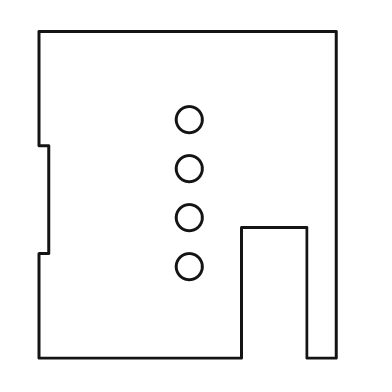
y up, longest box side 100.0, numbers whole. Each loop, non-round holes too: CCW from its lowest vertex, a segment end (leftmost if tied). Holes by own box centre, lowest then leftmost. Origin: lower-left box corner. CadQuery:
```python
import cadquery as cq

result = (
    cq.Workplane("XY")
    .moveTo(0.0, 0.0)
    .lineTo(62.0, 0.0)
    .lineTo(62.0, 40.0)
    .lineTo(82.0, 40.0)
    .lineTo(82.0, 0.0)
    .lineTo(91.0, 0.0)
    .lineTo(91.0, 100.0)
    .lineTo(0.0, 100.0)
    .lineTo(0.0, 65.0)
    .lineTo(3.0, 65.0)
    .lineTo(3.0, 32.0)
    .lineTo(0.0, 32.0)
    .close()
    .moveTo(46.0, 28.0)
    .circle(4.0)
    .moveTo(46.0, 43.0)
    .circle(4.0)
    .moveTo(46.0, 58.0)
    .circle(4.0)
    .moveTo(46.0, 73.0)
    .circle(4.0)
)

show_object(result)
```